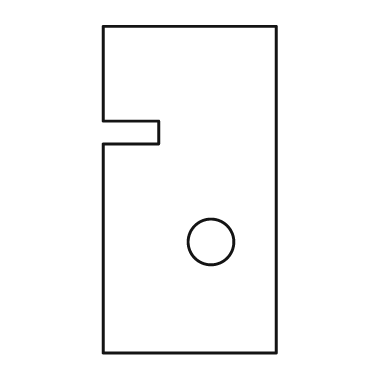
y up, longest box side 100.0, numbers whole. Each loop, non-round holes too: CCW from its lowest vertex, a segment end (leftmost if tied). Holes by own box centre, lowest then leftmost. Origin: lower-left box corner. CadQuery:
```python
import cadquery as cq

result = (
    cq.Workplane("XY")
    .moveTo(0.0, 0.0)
    .lineTo(53.0, 0.0)
    .lineTo(53.0, 100.0)
    .lineTo(0.0, 100.0)
    .lineTo(0.0, 71.0)
    .lineTo(17.0, 71.0)
    .lineTo(17.0, 64.0)
    .lineTo(0.0, 64.0)
    .close()
    .moveTo(33.0, 34.0)
    .circle(7.0)
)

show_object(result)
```